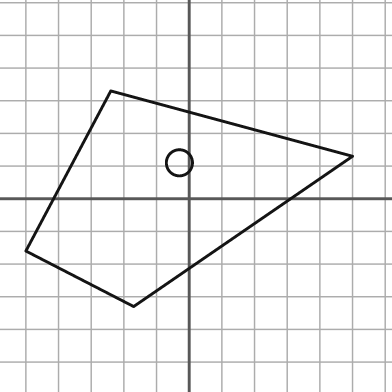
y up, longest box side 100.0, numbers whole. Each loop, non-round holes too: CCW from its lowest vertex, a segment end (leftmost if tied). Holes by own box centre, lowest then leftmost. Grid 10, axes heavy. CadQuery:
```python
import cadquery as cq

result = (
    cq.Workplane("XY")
    .moveTo(-17.0, -33.0)
    .lineTo(50.0, 13.0)
    .lineTo(-24.0, 33.0)
    .lineTo(-50.0, -16.0)
    .close()
    .moveTo(-3.0, 11.0)
    .circle(4.0)
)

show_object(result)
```